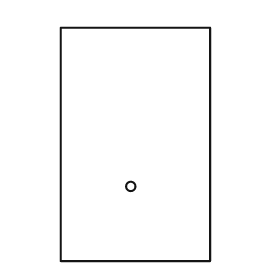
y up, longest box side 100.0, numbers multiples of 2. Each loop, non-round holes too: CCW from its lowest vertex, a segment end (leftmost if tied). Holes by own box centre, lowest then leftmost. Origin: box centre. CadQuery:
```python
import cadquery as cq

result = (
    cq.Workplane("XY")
    .moveTo(-32.0, -50.0)
    .lineTo(32.0, -50.0)
    .lineTo(32.0, 50.0)
    .lineTo(-32.0, 50.0)
    .close()
    .moveTo(-2.0, -18.0)
    .circle(2.0)
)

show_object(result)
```